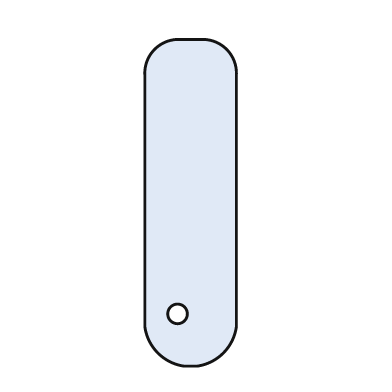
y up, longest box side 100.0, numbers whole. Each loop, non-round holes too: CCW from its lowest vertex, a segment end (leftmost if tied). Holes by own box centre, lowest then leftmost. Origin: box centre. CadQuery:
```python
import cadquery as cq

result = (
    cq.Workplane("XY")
    .moveTo(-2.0, -50.0)
    .lineTo(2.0, -50.0)
    .threePointArc((10.0, -46.0), (14.0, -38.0))
    .lineTo(14.0, 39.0)
    .threePointArc((11.0, 47.0), (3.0, 50.0))
    .lineTo(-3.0, 50.0)
    .threePointArc((-11.0, 47.0), (-14.0, 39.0))
    .lineTo(-14.0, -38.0)
    .threePointArc((-10.0, -46.0), (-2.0, -50.0))
    .close()
    .moveTo(-4.0, -34.0)
    .circle(3.0)
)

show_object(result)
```